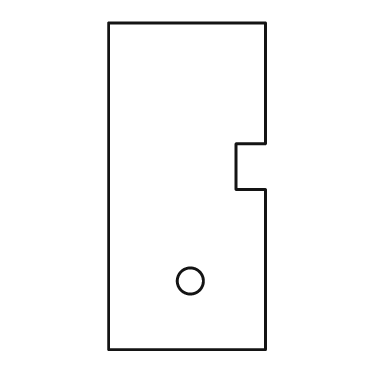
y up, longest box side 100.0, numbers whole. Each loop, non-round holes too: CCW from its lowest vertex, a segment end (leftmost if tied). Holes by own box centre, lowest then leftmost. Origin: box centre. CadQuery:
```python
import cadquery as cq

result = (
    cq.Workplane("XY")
    .moveTo(-24.0, -50.0)
    .lineTo(24.0, -50.0)
    .lineTo(24.0, -1.0)
    .lineTo(15.0, -1.0)
    .lineTo(15.0, 13.0)
    .lineTo(24.0, 13.0)
    .lineTo(24.0, 50.0)
    .lineTo(-24.0, 50.0)
    .close()
    .moveTo(1.0, -29.0)
    .circle(4.0)
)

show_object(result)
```